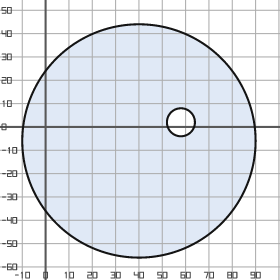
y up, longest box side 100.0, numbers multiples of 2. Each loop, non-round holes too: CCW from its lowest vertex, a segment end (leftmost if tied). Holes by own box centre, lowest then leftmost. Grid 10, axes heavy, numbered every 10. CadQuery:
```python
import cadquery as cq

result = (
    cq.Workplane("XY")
    .moveTo(40.0, -6.0)
    .circle(50.0)
    .moveTo(58.0, 2.0)
    .circle(6.0)
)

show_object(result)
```